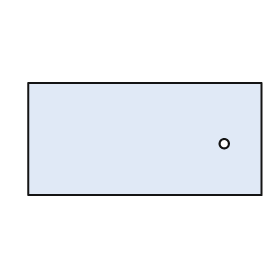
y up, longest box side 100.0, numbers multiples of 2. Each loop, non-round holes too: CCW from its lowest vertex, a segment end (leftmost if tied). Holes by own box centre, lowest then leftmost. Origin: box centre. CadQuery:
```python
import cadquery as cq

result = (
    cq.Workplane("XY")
    .moveTo(-50.0, -24.0)
    .lineTo(50.0, -24.0)
    .lineTo(50.0, 24.0)
    .lineTo(-50.0, 24.0)
    .close()
    .moveTo(34.0, -2.0)
    .circle(2.0)
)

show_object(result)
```